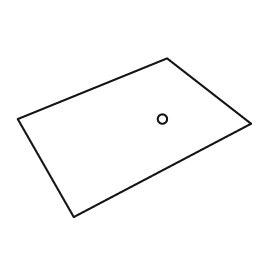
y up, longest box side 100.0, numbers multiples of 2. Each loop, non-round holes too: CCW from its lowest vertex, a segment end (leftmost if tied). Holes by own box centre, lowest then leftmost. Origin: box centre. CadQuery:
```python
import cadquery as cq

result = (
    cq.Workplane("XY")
    .moveTo(-26.0, -34.0)
    .lineTo(50.0, 6.0)
    .lineTo(14.0, 34.0)
    .lineTo(-50.0, 8.0)
    .close()
    .moveTo(12.0, 8.0)
    .circle(2.0)
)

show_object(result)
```